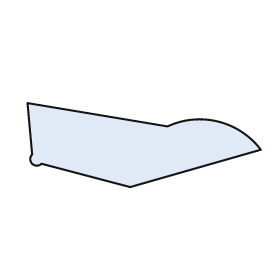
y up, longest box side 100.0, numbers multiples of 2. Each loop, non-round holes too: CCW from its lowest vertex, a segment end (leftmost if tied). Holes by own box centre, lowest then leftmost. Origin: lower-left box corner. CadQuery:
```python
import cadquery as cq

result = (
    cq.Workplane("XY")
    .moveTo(44.0, 0.0)
    .lineTo(100.0, 16.0)
    .threePointArc((82.0, 28.0), (60.0, 26.0))
    .lineTo(0.0, 36.0)
    .lineTo(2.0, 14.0)
    .threePointArc((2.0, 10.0), (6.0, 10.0))
    .close()
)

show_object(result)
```